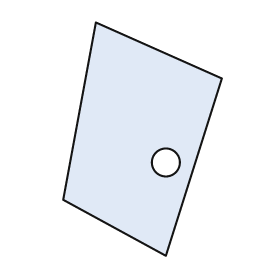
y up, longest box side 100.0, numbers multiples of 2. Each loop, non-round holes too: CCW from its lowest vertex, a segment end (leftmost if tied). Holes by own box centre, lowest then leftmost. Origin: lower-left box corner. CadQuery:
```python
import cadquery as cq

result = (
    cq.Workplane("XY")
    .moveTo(44.0, 0.0)
    .lineTo(68.0, 76.0)
    .lineTo(14.0, 100.0)
    .lineTo(0.0, 24.0)
    .close()
    .moveTo(44.0, 40.0)
    .circle(6.0)
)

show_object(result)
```